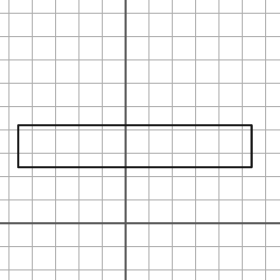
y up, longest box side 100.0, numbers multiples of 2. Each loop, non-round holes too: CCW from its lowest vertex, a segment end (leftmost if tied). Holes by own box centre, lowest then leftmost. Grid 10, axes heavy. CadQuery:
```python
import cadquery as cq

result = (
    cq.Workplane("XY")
    .moveTo(-46.0, 24.0)
    .lineTo(54.0, 24.0)
    .lineTo(54.0, 42.0)
    .lineTo(-46.0, 42.0)
    .close()
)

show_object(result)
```